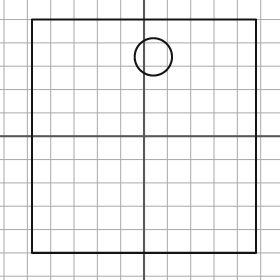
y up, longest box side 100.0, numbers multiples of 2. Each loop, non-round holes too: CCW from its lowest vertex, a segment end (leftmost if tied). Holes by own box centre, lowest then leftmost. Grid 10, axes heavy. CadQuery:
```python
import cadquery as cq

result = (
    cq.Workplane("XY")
    .moveTo(-48.0, -50.0)
    .lineTo(48.0, -50.0)
    .lineTo(48.0, 50.0)
    .lineTo(-48.0, 50.0)
    .close()
    .moveTo(4.0, 34.0)
    .circle(8.0)
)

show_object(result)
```